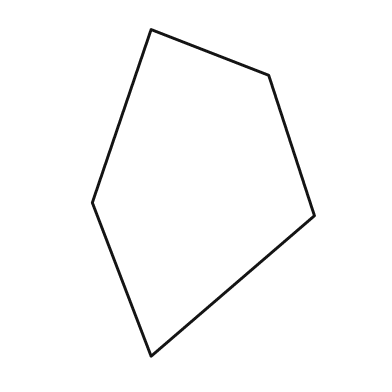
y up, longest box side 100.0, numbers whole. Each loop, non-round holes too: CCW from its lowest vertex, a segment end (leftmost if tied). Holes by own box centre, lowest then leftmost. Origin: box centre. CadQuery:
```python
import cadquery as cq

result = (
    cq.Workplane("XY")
    .moveTo(-16.0, -50.0)
    .lineTo(34.0, -7.0)
    .lineTo(20.0, 36.0)
    .lineTo(-16.0, 50.0)
    .lineTo(-34.0, -3.0)
    .close()
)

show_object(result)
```